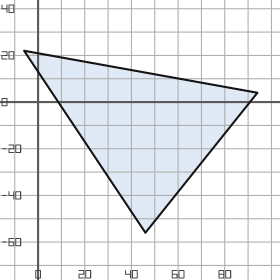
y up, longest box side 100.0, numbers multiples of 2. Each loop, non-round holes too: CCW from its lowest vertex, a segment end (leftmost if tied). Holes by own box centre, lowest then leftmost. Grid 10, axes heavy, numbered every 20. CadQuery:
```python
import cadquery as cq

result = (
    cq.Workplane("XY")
    .moveTo(46.0, -56.0)
    .lineTo(94.0, 4.0)
    .lineTo(-6.0, 22.0)
    .close()
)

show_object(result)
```